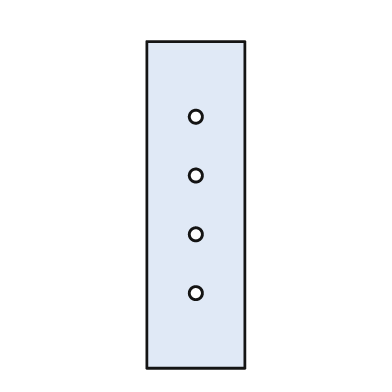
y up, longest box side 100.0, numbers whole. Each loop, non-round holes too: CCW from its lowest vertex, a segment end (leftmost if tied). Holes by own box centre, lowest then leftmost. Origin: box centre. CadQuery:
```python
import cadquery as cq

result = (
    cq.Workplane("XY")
    .moveTo(-15.0, -50.0)
    .lineTo(15.0, -50.0)
    .lineTo(15.0, 50.0)
    .lineTo(-15.0, 50.0)
    .close()
    .moveTo(0.0, -27.0)
    .circle(2.0)
    .moveTo(0.0, -9.0)
    .circle(2.0)
    .moveTo(0.0, 9.0)
    .circle(2.0)
    .moveTo(0.0, 27.0)
    .circle(2.0)
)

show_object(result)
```